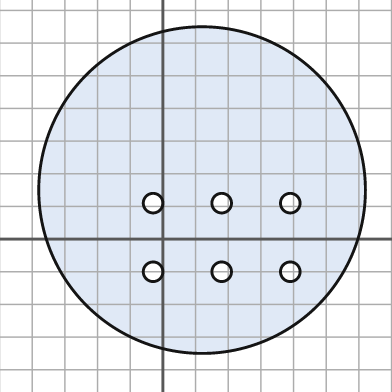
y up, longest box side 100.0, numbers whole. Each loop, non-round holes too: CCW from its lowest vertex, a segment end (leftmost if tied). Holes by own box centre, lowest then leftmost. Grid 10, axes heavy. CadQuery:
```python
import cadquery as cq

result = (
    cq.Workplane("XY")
    .moveTo(12.0, 15.0)
    .circle(50.0)
    .moveTo(-3.0, -10.0)
    .circle(3.0)
    .moveTo(18.0, -10.0)
    .circle(3.0)
    .moveTo(39.0, -10.0)
    .circle(3.0)
    .moveTo(-3.0, 11.0)
    .circle(3.0)
    .moveTo(18.0, 11.0)
    .circle(3.0)
    .moveTo(39.0, 11.0)
    .circle(3.0)
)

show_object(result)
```